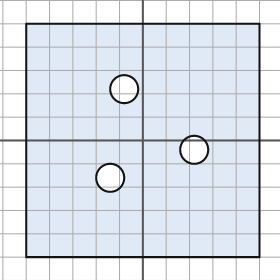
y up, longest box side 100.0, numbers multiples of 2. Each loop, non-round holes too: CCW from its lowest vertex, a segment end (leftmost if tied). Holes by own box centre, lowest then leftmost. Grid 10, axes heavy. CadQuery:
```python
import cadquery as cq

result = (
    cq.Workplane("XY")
    .moveTo(-50.0, -50.0)
    .lineTo(50.0, -50.0)
    .lineTo(50.0, 50.0)
    .lineTo(-50.0, 50.0)
    .close()
    .moveTo(-14.0, -16.0)
    .circle(6.0)
    .moveTo(22.0, -4.0)
    .circle(6.0)
    .moveTo(-8.0, 22.0)
    .circle(6.0)
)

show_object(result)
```